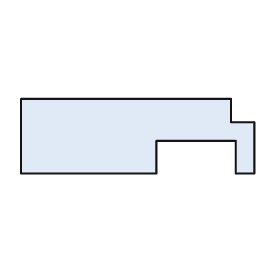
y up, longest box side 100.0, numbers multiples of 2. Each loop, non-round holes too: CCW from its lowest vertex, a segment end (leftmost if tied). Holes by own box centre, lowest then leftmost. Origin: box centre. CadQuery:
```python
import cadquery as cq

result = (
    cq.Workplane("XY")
    .moveTo(-50.0, -16.0)
    .lineTo(8.0, -16.0)
    .lineTo(8.0, -2.0)
    .lineTo(42.0, -2.0)
    .lineTo(42.0, -16.0)
    .lineTo(50.0, -16.0)
    .lineTo(50.0, 6.0)
    .lineTo(40.0, 6.0)
    .lineTo(40.0, 16.0)
    .lineTo(-50.0, 16.0)
    .close()
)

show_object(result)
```